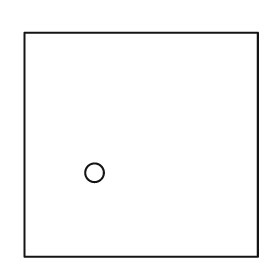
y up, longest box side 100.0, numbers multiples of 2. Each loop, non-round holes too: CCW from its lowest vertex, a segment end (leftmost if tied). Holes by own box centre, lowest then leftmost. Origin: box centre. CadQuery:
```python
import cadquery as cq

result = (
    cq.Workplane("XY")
    .moveTo(-50.0, -48.0)
    .lineTo(50.0, -48.0)
    .lineTo(50.0, 48.0)
    .lineTo(-50.0, 48.0)
    .close()
    .moveTo(-20.0, -12.0)
    .circle(4.0)
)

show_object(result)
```